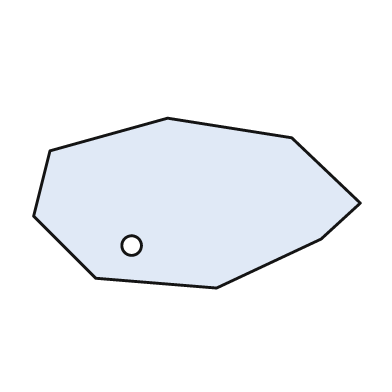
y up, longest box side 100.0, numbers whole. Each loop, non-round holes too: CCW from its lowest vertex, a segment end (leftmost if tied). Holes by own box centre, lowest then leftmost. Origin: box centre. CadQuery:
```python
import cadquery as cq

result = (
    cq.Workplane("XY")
    .moveTo(6.0, -26.0)
    .lineTo(38.0, -11.0)
    .lineTo(50.0, 0.0)
    .lineTo(29.0, 20.0)
    .lineTo(-9.0, 26.0)
    .lineTo(-45.0, 16.0)
    .lineTo(-50.0, -4.0)
    .lineTo(-31.0, -23.0)
    .close()
    .moveTo(-20.0, -13.0)
    .circle(3.0)
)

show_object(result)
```